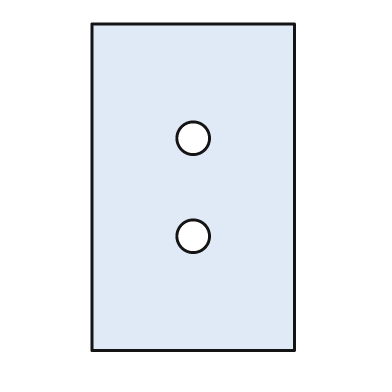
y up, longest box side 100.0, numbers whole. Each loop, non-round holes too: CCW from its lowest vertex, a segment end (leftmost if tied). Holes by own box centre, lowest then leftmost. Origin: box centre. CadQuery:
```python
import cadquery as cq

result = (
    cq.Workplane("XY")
    .moveTo(-31.0, -50.0)
    .lineTo(31.0, -50.0)
    .lineTo(31.0, 50.0)
    .lineTo(-31.0, 50.0)
    .close()
    .moveTo(0.0, -15.0)
    .circle(5.0)
    .moveTo(0.0, 15.0)
    .circle(5.0)
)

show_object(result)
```